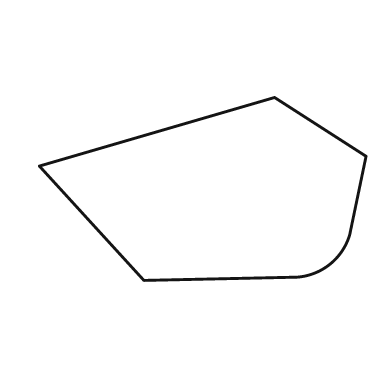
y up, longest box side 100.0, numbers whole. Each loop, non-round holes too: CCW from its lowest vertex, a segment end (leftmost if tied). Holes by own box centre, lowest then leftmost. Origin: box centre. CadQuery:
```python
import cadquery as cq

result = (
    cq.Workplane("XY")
    .moveTo(-18.0, -28.0)
    .lineTo(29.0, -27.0)
    .threePointArc((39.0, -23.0), (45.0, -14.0))
    .lineTo(50.0, 10.0)
    .lineTo(22.0, 28.0)
    .lineTo(-50.0, 7.0)
    .close()
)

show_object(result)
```